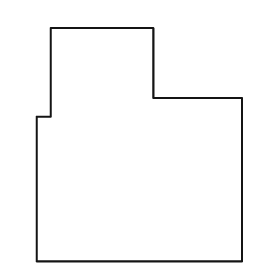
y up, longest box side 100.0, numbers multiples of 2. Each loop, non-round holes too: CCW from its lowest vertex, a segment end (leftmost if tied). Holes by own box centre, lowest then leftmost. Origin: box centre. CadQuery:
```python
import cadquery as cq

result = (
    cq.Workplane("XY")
    .moveTo(-44.0, -50.0)
    .lineTo(44.0, -50.0)
    .lineTo(44.0, 20.0)
    .lineTo(6.0, 20.0)
    .lineTo(6.0, 50.0)
    .lineTo(-38.0, 50.0)
    .lineTo(-38.0, 12.0)
    .lineTo(-44.0, 12.0)
    .close()
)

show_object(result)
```